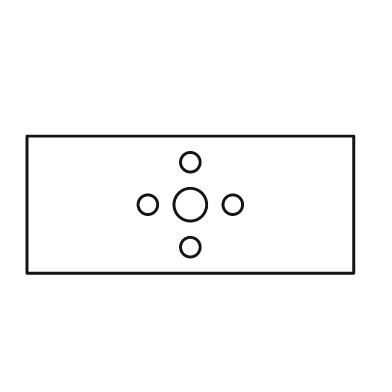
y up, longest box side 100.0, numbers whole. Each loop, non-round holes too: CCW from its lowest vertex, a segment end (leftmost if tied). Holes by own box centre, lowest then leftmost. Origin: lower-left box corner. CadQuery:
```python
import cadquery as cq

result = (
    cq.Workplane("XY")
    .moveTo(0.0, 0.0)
    .lineTo(100.0, 0.0)
    .lineTo(100.0, 42.0)
    .lineTo(0.0, 42.0)
    .close()
    .moveTo(50.0, 8.0)
    .circle(3.0)
    .moveTo(37.0, 21.0)
    .circle(3.0)
    .moveTo(50.0, 21.0)
    .circle(5.0)
    .moveTo(63.0, 21.0)
    .circle(3.0)
    .moveTo(50.0, 34.0)
    .circle(3.0)
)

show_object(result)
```